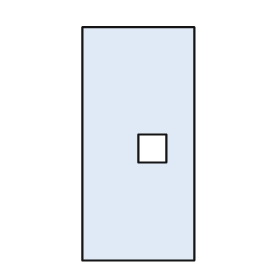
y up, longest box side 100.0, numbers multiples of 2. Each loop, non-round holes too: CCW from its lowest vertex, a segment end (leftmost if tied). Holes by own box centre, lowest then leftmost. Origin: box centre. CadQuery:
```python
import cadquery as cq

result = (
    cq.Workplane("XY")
    .moveTo(-24.0, -50.0)
    .lineTo(24.0, -50.0)
    .lineTo(24.0, 50.0)
    .lineTo(-24.0, 50.0)
    .close()
    .moveTo(0.0, -8.0)
    .lineTo(12.0, -8.0)
    .lineTo(12.0, 4.0)
    .lineTo(0.0, 4.0)
    .close()
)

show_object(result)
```